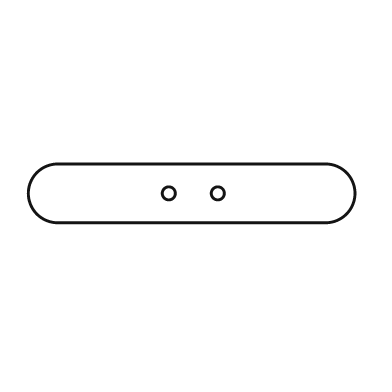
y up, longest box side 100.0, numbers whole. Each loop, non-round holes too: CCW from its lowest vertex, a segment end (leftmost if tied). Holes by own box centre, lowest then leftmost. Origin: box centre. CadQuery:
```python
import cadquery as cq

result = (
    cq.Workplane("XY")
    .moveTo(-41.0, -9.0)
    .lineTo(41.0, -9.0)
    .threePointArc((50.0, 0.0), (41.0, 9.0))
    .lineTo(-41.0, 9.0)
    .threePointArc((-50.0, 0.0), (-41.0, -9.0))
    .close()
    .moveTo(-7.0, 0.0)
    .circle(2.0)
    .moveTo(8.0, 0.0)
    .circle(2.0)
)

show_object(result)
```